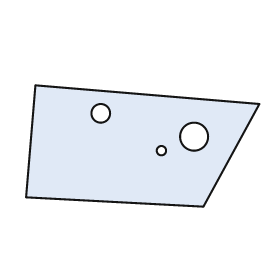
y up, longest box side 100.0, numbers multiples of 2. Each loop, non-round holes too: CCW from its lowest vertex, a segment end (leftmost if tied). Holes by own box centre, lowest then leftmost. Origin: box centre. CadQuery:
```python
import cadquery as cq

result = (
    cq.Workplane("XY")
    .moveTo(26.0, -26.0)
    .lineTo(50.0, 18.0)
    .lineTo(-46.0, 26.0)
    .lineTo(-50.0, -22.0)
    .close()
    .moveTo(8.0, -2.0)
    .circle(2.0)
    .moveTo(22.0, 4.0)
    .circle(6.0)
    .moveTo(-18.0, 14.0)
    .circle(4.0)
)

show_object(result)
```